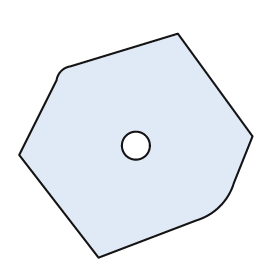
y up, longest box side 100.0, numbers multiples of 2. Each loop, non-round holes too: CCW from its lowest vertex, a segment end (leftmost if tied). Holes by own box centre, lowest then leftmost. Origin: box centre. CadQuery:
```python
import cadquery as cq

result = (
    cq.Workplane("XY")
    .moveTo(-16.0, -48.0)
    .lineTo(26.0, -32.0)
    .threePointArc((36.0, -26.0), (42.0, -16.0))
    .lineTo(50.0, 4.0)
    .lineTo(18.0, 48.0)
    .lineTo(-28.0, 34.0)
    .threePointArc((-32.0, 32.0), (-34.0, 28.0))
    .lineTo(-50.0, -4.0)
    .close()
    .moveTo(0.0, 0.0)
    .circle(6.0)
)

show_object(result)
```